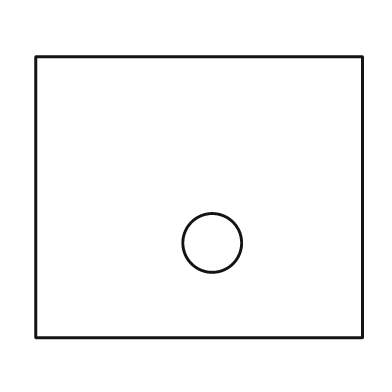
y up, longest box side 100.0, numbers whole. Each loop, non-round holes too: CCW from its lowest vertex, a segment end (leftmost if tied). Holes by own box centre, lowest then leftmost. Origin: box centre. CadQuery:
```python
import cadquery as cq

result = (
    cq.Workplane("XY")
    .moveTo(-50.0, -43.0)
    .lineTo(50.0, -43.0)
    .lineTo(50.0, 43.0)
    .lineTo(-50.0, 43.0)
    .close()
    .moveTo(4.0, -14.0)
    .circle(9.0)
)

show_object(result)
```